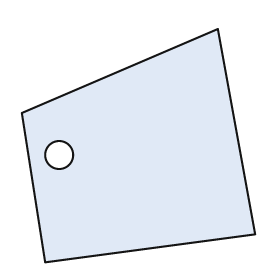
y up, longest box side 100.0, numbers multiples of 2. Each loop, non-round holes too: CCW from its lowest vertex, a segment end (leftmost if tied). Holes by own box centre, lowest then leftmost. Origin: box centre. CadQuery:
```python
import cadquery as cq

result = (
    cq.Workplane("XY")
    .moveTo(-40.0, -50.0)
    .lineTo(50.0, -38.0)
    .lineTo(34.0, 50.0)
    .lineTo(-50.0, 14.0)
    .close()
    .moveTo(-34.0, -4.0)
    .circle(6.0)
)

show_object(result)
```